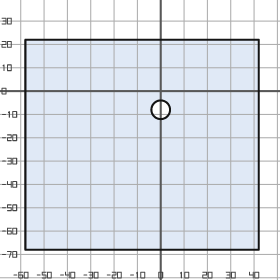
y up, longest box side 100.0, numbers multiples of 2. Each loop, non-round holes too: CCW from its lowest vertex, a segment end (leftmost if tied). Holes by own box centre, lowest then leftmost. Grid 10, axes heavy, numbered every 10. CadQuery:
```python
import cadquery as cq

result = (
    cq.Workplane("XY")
    .moveTo(-58.0, -68.0)
    .lineTo(42.0, -68.0)
    .lineTo(42.0, 22.0)
    .lineTo(-58.0, 22.0)
    .close()
    .moveTo(0.0, -8.0)
    .circle(4.0)
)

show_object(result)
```